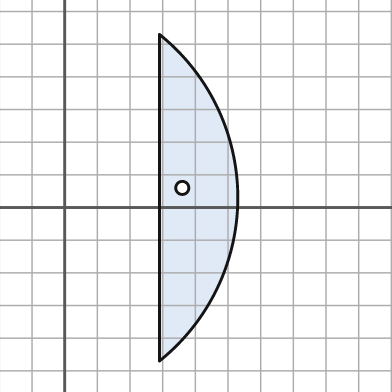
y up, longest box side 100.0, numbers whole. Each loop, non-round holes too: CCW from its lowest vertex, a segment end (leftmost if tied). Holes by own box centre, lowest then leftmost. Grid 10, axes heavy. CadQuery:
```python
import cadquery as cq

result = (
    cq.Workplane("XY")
    .moveTo(29.0, -47.0)
    .threePointArc((53.0, 3.0), (29.0, 53.0))
    .close()
    .moveTo(36.0, 6.0)
    .circle(2.0)
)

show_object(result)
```